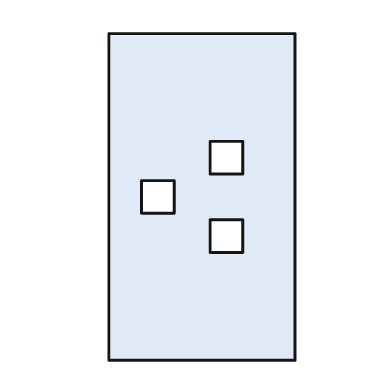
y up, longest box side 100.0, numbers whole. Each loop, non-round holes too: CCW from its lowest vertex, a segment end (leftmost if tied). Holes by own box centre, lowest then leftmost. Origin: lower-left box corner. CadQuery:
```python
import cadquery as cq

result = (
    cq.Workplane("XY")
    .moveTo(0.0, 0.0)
    .lineTo(57.0, 0.0)
    .lineTo(57.0, 100.0)
    .lineTo(0.0, 100.0)
    .close()
    .moveTo(31.0, 33.0)
    .lineTo(41.0, 33.0)
    .lineTo(41.0, 43.0)
    .lineTo(31.0, 43.0)
    .close()
    .moveTo(10.0, 45.0)
    .lineTo(20.0, 45.0)
    .lineTo(20.0, 55.0)
    .lineTo(10.0, 55.0)
    .close()
    .moveTo(31.0, 57.0)
    .lineTo(41.0, 57.0)
    .lineTo(41.0, 67.0)
    .lineTo(31.0, 67.0)
    .close()
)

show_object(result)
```